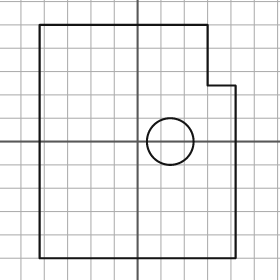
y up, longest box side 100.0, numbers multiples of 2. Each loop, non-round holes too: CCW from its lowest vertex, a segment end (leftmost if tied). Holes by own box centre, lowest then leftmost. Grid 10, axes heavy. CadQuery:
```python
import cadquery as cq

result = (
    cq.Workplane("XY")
    .moveTo(-42.0, -50.0)
    .lineTo(42.0, -50.0)
    .lineTo(42.0, 24.0)
    .lineTo(30.0, 24.0)
    .lineTo(30.0, 50.0)
    .lineTo(-42.0, 50.0)
    .close()
    .moveTo(14.0, 0.0)
    .circle(10.0)
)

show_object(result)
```